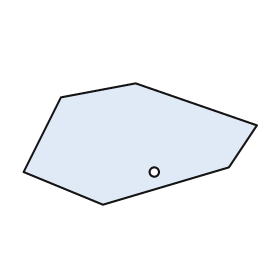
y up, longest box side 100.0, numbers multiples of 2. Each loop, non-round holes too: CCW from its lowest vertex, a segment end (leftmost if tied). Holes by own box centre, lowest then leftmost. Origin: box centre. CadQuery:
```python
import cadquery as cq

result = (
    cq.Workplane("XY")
    .moveTo(-16.0, -26.0)
    .lineTo(38.0, -10.0)
    .lineTo(50.0, 8.0)
    .lineTo(-2.0, 26.0)
    .lineTo(-34.0, 20.0)
    .lineTo(-50.0, -12.0)
    .close()
    .moveTo(6.0, -12.0)
    .circle(2.0)
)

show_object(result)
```